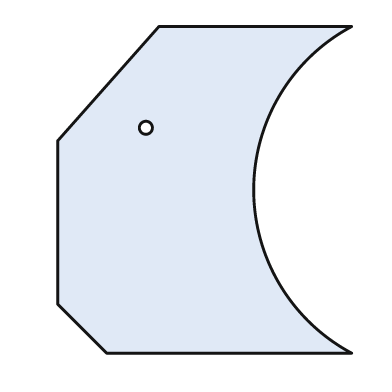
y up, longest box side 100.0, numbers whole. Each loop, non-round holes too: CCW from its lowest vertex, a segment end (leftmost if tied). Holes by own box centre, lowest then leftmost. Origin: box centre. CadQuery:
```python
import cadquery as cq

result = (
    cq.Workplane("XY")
    .moveTo(-30.0, -50.0)
    .lineTo(45.0, -50.0)
    .threePointArc((15.0, 0.0), (45.0, 50.0))
    .lineTo(-14.0, 50.0)
    .lineTo(-45.0, 15.0)
    .lineTo(-45.0, -35.0)
    .close()
    .moveTo(-18.0, 19.0)
    .circle(2.0)
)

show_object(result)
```